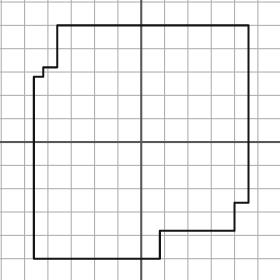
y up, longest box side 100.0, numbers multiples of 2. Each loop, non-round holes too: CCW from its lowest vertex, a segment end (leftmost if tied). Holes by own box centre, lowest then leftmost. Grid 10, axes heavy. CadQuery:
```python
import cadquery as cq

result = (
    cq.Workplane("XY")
    .moveTo(-46.0, -50.0)
    .lineTo(8.0, -50.0)
    .lineTo(8.0, -38.0)
    .lineTo(40.0, -38.0)
    .lineTo(40.0, -26.0)
    .lineTo(46.0, -26.0)
    .lineTo(46.0, 50.0)
    .lineTo(-36.0, 50.0)
    .lineTo(-36.0, 32.0)
    .lineTo(-42.0, 32.0)
    .lineTo(-42.0, 28.0)
    .lineTo(-46.0, 28.0)
    .close()
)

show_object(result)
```